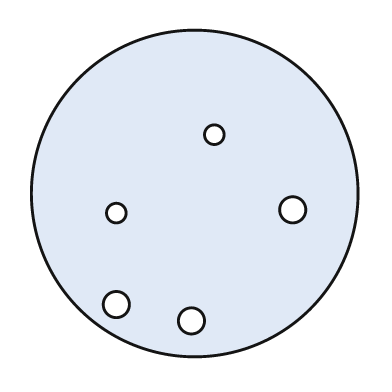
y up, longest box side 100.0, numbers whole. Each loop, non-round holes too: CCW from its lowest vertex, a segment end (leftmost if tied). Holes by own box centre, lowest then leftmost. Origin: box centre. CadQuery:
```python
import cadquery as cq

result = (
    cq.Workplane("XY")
    .moveTo(0.0, 0.0)
    .circle(50.0)
    .moveTo(-1.0, -39.0)
    .circle(4.0)
    .moveTo(-24.0, -34.0)
    .circle(4.0)
    .moveTo(-24.0, -6.0)
    .circle(3.0)
    .moveTo(30.0, -5.0)
    .circle(4.0)
    .moveTo(6.0, 18.0)
    .circle(3.0)
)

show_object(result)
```